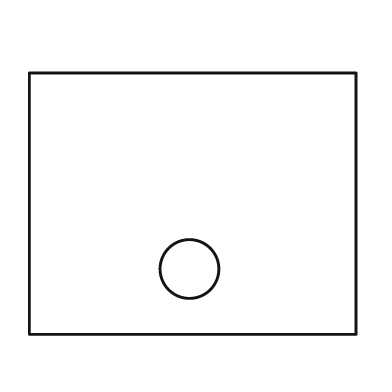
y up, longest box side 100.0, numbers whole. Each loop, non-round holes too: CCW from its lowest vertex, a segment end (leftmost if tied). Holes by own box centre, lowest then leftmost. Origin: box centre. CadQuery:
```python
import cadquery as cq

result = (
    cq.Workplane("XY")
    .moveTo(-50.0, -40.0)
    .lineTo(50.0, -40.0)
    .lineTo(50.0, 40.0)
    .lineTo(-50.0, 40.0)
    .close()
    .moveTo(-1.0, -20.0)
    .circle(9.0)
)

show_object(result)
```